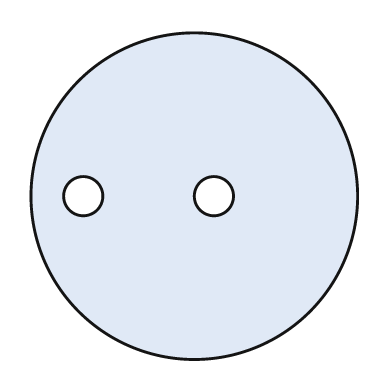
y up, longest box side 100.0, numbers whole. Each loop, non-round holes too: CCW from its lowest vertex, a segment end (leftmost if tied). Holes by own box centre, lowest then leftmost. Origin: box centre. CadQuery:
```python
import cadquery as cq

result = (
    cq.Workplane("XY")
    .moveTo(0.0, 0.0)
    .circle(50.0)
    .moveTo(-34.0, 0.0)
    .circle(6.0)
    .moveTo(6.0, 0.0)
    .circle(6.0)
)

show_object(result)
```